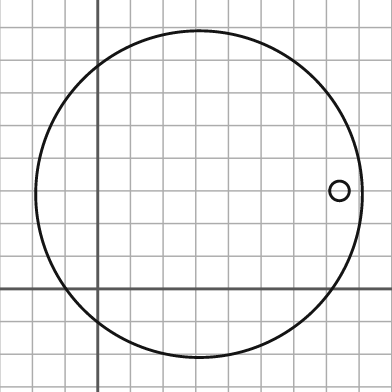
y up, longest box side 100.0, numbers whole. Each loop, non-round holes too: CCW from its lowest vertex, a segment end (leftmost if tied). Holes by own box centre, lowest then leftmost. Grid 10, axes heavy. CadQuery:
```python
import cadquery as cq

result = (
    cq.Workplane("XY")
    .moveTo(31.0, 29.0)
    .circle(50.0)
    .moveTo(74.0, 30.0)
    .circle(3.0)
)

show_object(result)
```